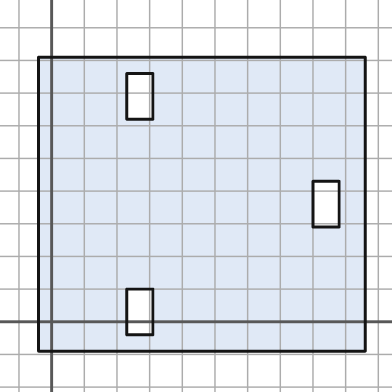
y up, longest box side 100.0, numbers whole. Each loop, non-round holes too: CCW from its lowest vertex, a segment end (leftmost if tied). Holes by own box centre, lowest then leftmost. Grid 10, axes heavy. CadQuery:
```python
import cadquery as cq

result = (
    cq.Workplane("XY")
    .moveTo(-4.0, -9.0)
    .lineTo(96.0, -9.0)
    .lineTo(96.0, 81.0)
    .lineTo(-4.0, 81.0)
    .close()
    .moveTo(23.0, -4.0)
    .lineTo(31.0, -4.0)
    .lineTo(31.0, 10.0)
    .lineTo(23.0, 10.0)
    .close()
    .moveTo(80.0, 29.0)
    .lineTo(88.0, 29.0)
    .lineTo(88.0, 43.0)
    .lineTo(80.0, 43.0)
    .close()
    .moveTo(23.0, 62.0)
    .lineTo(31.0, 62.0)
    .lineTo(31.0, 76.0)
    .lineTo(23.0, 76.0)
    .close()
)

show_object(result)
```